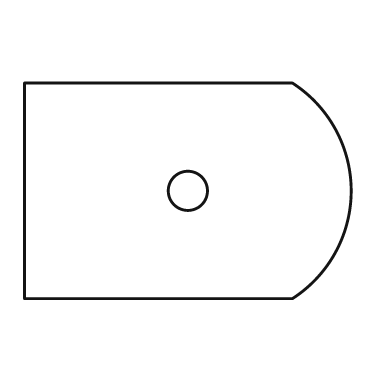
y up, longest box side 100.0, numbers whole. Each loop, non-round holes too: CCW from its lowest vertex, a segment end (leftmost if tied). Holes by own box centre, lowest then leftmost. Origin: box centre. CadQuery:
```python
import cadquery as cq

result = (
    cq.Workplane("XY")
    .moveTo(-50.0, -33.0)
    .lineTo(32.0, -33.0)
    .threePointArc((50.0, 0.0), (32.0, 33.0))
    .lineTo(-50.0, 33.0)
    .close()
    .moveTo(0.0, 0.0)
    .circle(6.0)
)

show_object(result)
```